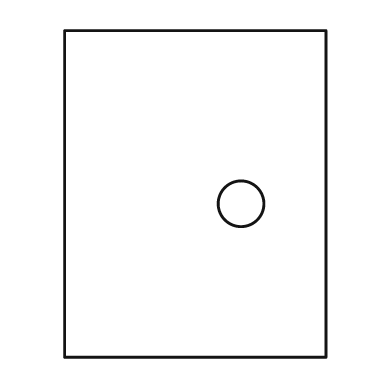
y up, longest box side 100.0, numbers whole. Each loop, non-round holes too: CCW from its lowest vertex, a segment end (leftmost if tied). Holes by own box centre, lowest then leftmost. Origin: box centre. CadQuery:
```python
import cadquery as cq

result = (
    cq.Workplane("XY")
    .moveTo(-40.0, -50.0)
    .lineTo(40.0, -50.0)
    .lineTo(40.0, 50.0)
    .lineTo(-40.0, 50.0)
    .close()
    .moveTo(14.0, -3.0)
    .circle(7.0)
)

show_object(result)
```